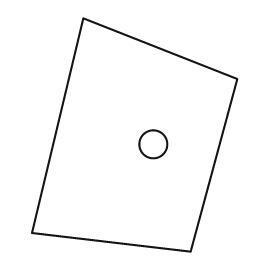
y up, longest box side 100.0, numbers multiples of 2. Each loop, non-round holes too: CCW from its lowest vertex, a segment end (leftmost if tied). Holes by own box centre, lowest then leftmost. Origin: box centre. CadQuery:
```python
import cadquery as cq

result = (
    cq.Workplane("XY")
    .moveTo(24.0, -50.0)
    .lineTo(44.0, 24.0)
    .lineTo(-22.0, 50.0)
    .lineTo(-44.0, -42.0)
    .close()
    .moveTo(8.0, -4.0)
    .circle(6.0)
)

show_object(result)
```